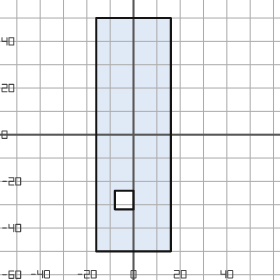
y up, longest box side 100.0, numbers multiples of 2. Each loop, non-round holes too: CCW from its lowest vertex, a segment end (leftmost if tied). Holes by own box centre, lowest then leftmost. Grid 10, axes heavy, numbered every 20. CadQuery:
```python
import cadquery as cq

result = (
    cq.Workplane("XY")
    .moveTo(-16.0, -50.0)
    .lineTo(16.0, -50.0)
    .lineTo(16.0, 50.0)
    .lineTo(-16.0, 50.0)
    .close()
    .moveTo(-8.0, -32.0)
    .lineTo(0.0, -32.0)
    .lineTo(0.0, -24.0)
    .lineTo(-8.0, -24.0)
    .close()
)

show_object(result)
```